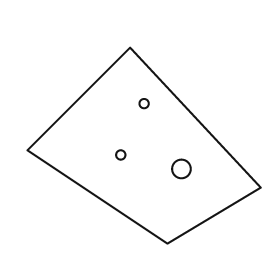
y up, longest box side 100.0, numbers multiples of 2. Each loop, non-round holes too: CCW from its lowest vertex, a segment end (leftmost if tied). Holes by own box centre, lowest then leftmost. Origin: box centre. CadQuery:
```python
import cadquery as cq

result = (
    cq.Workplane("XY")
    .moveTo(10.0, -42.0)
    .lineTo(50.0, -18.0)
    .lineTo(-6.0, 42.0)
    .lineTo(-50.0, -2.0)
    .close()
    .moveTo(16.0, -10.0)
    .circle(4.0)
    .moveTo(-10.0, -4.0)
    .circle(2.0)
    .moveTo(0.0, 18.0)
    .circle(2.0)
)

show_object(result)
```